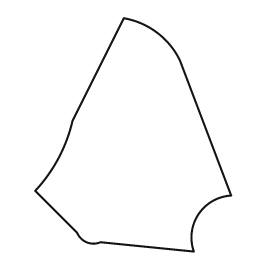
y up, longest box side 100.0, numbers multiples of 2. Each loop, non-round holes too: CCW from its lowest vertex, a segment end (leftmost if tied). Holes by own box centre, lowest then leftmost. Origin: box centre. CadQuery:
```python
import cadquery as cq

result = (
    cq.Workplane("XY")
    .moveTo(26.0, -50.0)
    .threePointArc((28.0, -34.0), (42.0, -26.0))
    .lineTo(20.0, 32.0)
    .threePointArc((10.0, 44.0), (-4.0, 50.0))
    .lineTo(-26.0, 6.0)
    .threePointArc((-32.0, -10.0), (-42.0, -24.0))
    .lineTo(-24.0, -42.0)
    .threePointArc((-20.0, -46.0), (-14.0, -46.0))
    .close()
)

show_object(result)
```